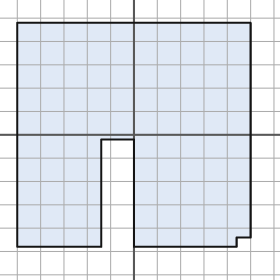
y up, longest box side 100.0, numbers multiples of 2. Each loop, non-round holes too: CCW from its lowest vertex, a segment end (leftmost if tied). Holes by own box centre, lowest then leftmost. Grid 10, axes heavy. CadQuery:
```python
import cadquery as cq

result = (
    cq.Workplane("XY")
    .moveTo(-50.0, -48.0)
    .lineTo(-14.0, -48.0)
    .lineTo(-14.0, -2.0)
    .lineTo(0.0, -2.0)
    .lineTo(0.0, -48.0)
    .lineTo(44.0, -48.0)
    .lineTo(44.0, -44.0)
    .lineTo(50.0, -44.0)
    .lineTo(50.0, 48.0)
    .lineTo(-50.0, 48.0)
    .close()
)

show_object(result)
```